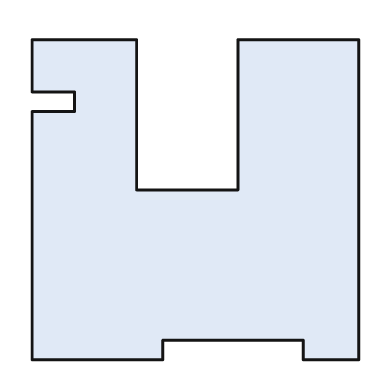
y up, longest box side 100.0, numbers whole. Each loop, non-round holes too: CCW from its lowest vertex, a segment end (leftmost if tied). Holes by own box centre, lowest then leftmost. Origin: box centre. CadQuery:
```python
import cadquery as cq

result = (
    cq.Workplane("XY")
    .moveTo(-50.0, -49.0)
    .lineTo(-10.0, -49.0)
    .lineTo(-10.0, -43.0)
    .lineTo(33.0, -43.0)
    .lineTo(33.0, -49.0)
    .lineTo(50.0, -49.0)
    .lineTo(50.0, 49.0)
    .lineTo(13.0, 49.0)
    .lineTo(13.0, 3.0)
    .lineTo(-18.0, 3.0)
    .lineTo(-18.0, 49.0)
    .lineTo(-50.0, 49.0)
    .lineTo(-50.0, 33.0)
    .lineTo(-37.0, 33.0)
    .lineTo(-37.0, 27.0)
    .lineTo(-50.0, 27.0)
    .close()
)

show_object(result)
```